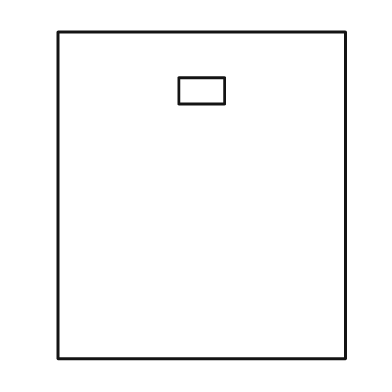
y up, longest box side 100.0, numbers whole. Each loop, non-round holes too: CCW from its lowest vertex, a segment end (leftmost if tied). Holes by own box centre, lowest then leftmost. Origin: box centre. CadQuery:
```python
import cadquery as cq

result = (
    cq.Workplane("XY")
    .moveTo(-44.0, -50.0)
    .lineTo(44.0, -50.0)
    .lineTo(44.0, 50.0)
    .lineTo(-44.0, 50.0)
    .close()
    .moveTo(-7.0, 28.0)
    .lineTo(7.0, 28.0)
    .lineTo(7.0, 36.0)
    .lineTo(-7.0, 36.0)
    .close()
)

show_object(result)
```